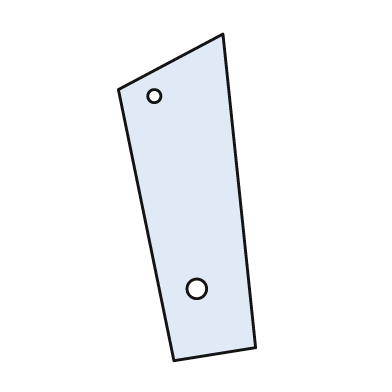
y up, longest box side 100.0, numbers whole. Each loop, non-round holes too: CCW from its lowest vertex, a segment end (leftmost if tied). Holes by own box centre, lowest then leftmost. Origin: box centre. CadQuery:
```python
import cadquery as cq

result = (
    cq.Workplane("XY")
    .moveTo(-4.0, -50.0)
    .lineTo(21.0, -46.0)
    .lineTo(11.0, 50.0)
    .lineTo(-21.0, 33.0)
    .close()
    .moveTo(3.0, -28.0)
    .circle(3.0)
    .moveTo(-10.0, 31.0)
    .circle(2.0)
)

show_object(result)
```